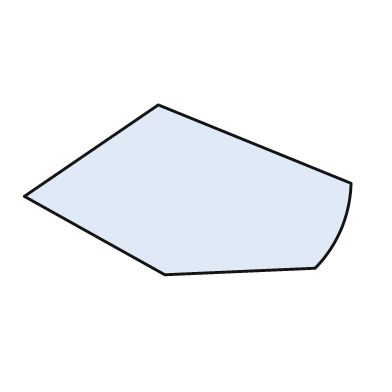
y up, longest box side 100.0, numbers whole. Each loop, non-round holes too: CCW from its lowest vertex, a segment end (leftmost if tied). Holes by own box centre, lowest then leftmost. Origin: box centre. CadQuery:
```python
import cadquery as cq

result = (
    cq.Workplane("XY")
    .moveTo(-7.0, -26.0)
    .lineTo(39.0, -24.0)
    .threePointArc((47.0, -12.0), (50.0, 2.0))
    .lineTo(-9.0, 26.0)
    .lineTo(-50.0, -2.0)
    .close()
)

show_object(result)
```